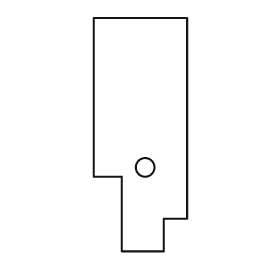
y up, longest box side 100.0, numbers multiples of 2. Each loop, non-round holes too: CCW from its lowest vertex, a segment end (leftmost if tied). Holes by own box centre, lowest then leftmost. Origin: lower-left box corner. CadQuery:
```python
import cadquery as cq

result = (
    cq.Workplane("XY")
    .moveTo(12.0, 0.0)
    .lineTo(30.0, 0.0)
    .lineTo(30.0, 14.0)
    .lineTo(40.0, 14.0)
    .lineTo(40.0, 100.0)
    .lineTo(0.0, 100.0)
    .lineTo(0.0, 32.0)
    .lineTo(12.0, 32.0)
    .close()
    .moveTo(22.0, 36.0)
    .circle(4.0)
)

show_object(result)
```